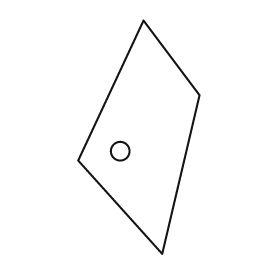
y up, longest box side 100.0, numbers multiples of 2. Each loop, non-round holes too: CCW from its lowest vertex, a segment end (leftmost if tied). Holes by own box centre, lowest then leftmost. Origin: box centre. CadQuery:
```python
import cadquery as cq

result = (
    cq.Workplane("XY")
    .moveTo(10.0, -50.0)
    .lineTo(26.0, 18.0)
    .lineTo(2.0, 50.0)
    .lineTo(-26.0, -10.0)
    .close()
    .moveTo(-8.0, -6.0)
    .circle(4.0)
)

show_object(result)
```